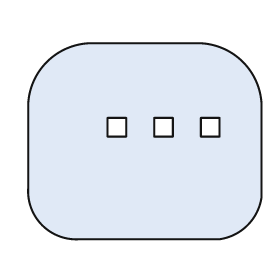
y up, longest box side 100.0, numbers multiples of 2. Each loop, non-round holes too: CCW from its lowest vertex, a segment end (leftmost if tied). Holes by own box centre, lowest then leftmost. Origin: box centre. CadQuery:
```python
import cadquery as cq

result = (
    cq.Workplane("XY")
    .moveTo(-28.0, -42.0)
    .lineTo(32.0, -42.0)
    .threePointArc((44.0, -36.0), (50.0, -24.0))
    .lineTo(50.0, 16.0)
    .threePointArc((42.0, 34.0), (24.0, 42.0))
    .lineTo(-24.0, 42.0)
    .threePointArc((-42.0, 34.0), (-50.0, 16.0))
    .lineTo(-50.0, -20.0)
    .threePointArc((-44.0, -36.0), (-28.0, -42.0))
    .close()
    .moveTo(-16.0, 2.0)
    .lineTo(-8.0, 2.0)
    .lineTo(-8.0, 10.0)
    .lineTo(-16.0, 10.0)
    .close()
    .moveTo(4.0, 2.0)
    .lineTo(12.0, 2.0)
    .lineTo(12.0, 10.0)
    .lineTo(4.0, 10.0)
    .close()
    .moveTo(24.0, 2.0)
    .lineTo(32.0, 2.0)
    .lineTo(32.0, 10.0)
    .lineTo(24.0, 10.0)
    .close()
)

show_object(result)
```